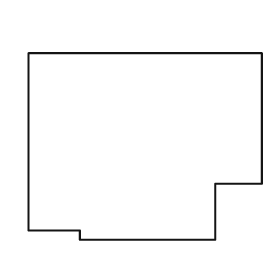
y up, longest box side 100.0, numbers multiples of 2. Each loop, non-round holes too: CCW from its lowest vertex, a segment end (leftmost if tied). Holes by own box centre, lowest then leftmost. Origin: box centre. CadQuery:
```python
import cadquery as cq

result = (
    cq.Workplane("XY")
    .moveTo(-28.0, -40.0)
    .lineTo(30.0, -40.0)
    .lineTo(30.0, -16.0)
    .lineTo(50.0, -16.0)
    .lineTo(50.0, 40.0)
    .lineTo(-50.0, 40.0)
    .lineTo(-50.0, -36.0)
    .lineTo(-28.0, -36.0)
    .close()
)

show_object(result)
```